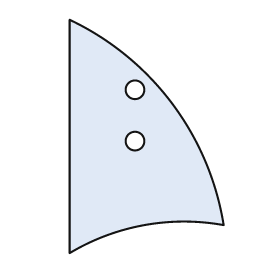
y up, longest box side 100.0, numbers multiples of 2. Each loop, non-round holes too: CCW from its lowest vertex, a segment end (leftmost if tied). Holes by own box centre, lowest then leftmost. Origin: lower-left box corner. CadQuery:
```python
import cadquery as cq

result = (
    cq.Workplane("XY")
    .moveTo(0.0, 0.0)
    .threePointArc((32.0, 12.0), (66.0, 12.0))
    .threePointArc((44.0, 64.0), (0.0, 100.0))
    .close()
    .moveTo(28.0, 48.0)
    .circle(4.0)
    .moveTo(28.0, 70.0)
    .circle(4.0)
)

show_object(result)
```